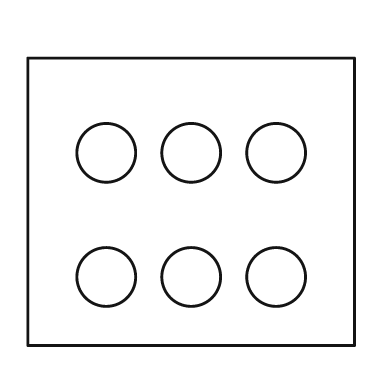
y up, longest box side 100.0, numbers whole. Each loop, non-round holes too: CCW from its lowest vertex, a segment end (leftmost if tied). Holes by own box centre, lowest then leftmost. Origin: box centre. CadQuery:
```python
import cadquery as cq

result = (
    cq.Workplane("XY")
    .moveTo(-50.0, -44.0)
    .lineTo(50.0, -44.0)
    .lineTo(50.0, 44.0)
    .lineTo(-50.0, 44.0)
    .close()
    .moveTo(-26.0, -23.0)
    .circle(9.0)
    .moveTo(0.0, -23.0)
    .circle(9.0)
    .moveTo(26.0, -23.0)
    .circle(9.0)
    .moveTo(-26.0, 15.0)
    .circle(9.0)
    .moveTo(0.0, 15.0)
    .circle(9.0)
    .moveTo(26.0, 15.0)
    .circle(9.0)
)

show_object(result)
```